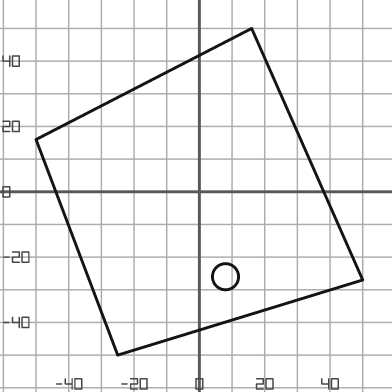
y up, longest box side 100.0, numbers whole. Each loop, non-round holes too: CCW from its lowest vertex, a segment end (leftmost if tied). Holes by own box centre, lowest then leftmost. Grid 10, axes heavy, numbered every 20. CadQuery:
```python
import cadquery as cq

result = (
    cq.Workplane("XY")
    .moveTo(-25.0, -50.0)
    .lineTo(50.0, -27.0)
    .lineTo(16.0, 50.0)
    .lineTo(-50.0, 16.0)
    .close()
    .moveTo(8.0, -26.0)
    .circle(4.0)
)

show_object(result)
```